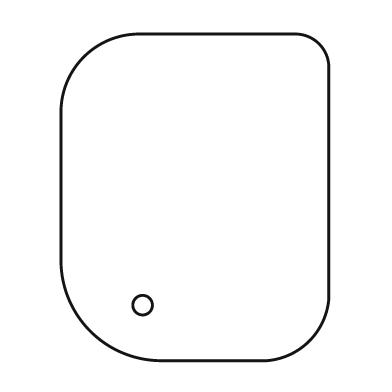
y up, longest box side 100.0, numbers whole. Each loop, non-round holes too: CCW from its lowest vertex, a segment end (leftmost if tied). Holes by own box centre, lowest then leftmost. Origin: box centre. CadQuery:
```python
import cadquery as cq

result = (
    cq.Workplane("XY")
    .moveTo(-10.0, -50.0)
    .lineTo(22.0, -50.0)
    .threePointArc((35.0, -44.0), (41.0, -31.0))
    .lineTo(41.0, 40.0)
    .threePointArc((38.0, 47.0), (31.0, 50.0))
    .lineTo(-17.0, 50.0)
    .threePointArc((-34.0, 43.0), (-41.0, 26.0))
    .lineTo(-41.0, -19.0)
    .threePointArc((-32.0, -41.0), (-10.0, -50.0))
    .close()
    .moveTo(-16.0, -33.0)
    .circle(3.0)
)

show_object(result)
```